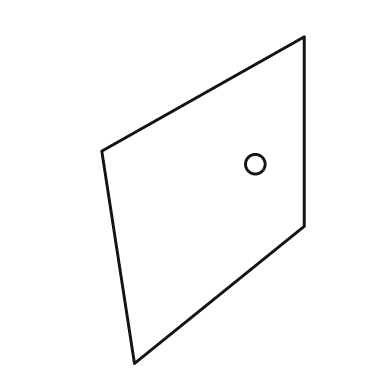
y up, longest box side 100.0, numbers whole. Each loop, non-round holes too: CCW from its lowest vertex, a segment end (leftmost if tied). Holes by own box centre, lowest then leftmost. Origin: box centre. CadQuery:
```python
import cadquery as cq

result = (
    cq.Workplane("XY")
    .moveTo(-21.0, -50.0)
    .lineTo(31.0, -8.0)
    .lineTo(31.0, 50.0)
    .lineTo(-31.0, 15.0)
    .close()
    .moveTo(16.0, 11.0)
    .circle(3.0)
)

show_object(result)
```